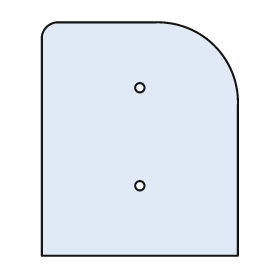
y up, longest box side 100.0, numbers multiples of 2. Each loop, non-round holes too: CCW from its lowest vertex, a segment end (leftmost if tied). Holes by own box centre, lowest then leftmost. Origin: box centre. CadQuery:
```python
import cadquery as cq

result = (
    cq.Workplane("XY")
    .moveTo(-42.0, -50.0)
    .lineTo(42.0, -50.0)
    .lineTo(42.0, 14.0)
    .threePointArc((32.0, 40.0), (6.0, 50.0))
    .lineTo(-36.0, 50.0)
    .threePointArc((-40.0, 48.0), (-42.0, 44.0))
    .close()
    .moveTo(0.0, -20.0)
    .circle(2.0)
    .moveTo(0.0, 22.0)
    .circle(2.0)
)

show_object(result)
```